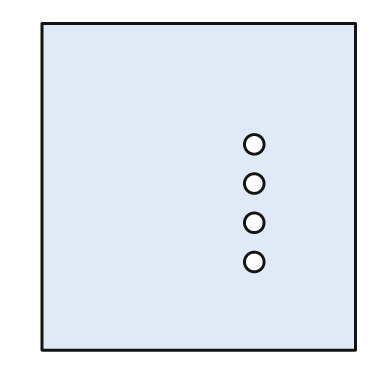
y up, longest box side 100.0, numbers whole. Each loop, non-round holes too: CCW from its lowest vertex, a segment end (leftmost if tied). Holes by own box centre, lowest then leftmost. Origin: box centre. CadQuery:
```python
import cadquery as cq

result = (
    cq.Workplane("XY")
    .moveTo(-48.0, -50.0)
    .lineTo(48.0, -50.0)
    .lineTo(48.0, 50.0)
    .lineTo(-48.0, 50.0)
    .close()
    .moveTo(17.0, -23.0)
    .circle(3.0)
    .moveTo(17.0, -11.0)
    .circle(3.0)
    .moveTo(17.0, 1.0)
    .circle(3.0)
    .moveTo(17.0, 13.0)
    .circle(3.0)
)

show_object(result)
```